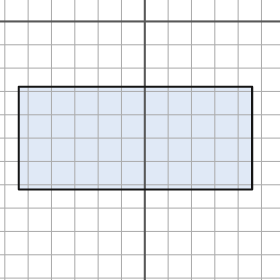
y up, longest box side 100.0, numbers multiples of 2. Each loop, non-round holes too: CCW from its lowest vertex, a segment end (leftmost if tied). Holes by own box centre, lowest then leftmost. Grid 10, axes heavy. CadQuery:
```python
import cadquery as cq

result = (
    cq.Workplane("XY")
    .moveTo(-54.0, -72.0)
    .lineTo(46.0, -72.0)
    .lineTo(46.0, -28.0)
    .lineTo(-54.0, -28.0)
    .close()
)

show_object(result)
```